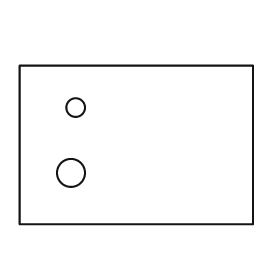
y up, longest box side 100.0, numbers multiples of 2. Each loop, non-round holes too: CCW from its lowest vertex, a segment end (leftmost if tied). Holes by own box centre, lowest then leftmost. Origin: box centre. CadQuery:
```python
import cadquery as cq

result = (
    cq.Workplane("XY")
    .moveTo(-50.0, -34.0)
    .lineTo(50.0, -34.0)
    .lineTo(50.0, 34.0)
    .lineTo(-50.0, 34.0)
    .close()
    .moveTo(-28.0, -12.0)
    .circle(6.0)
    .moveTo(-26.0, 16.0)
    .circle(4.0)
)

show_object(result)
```